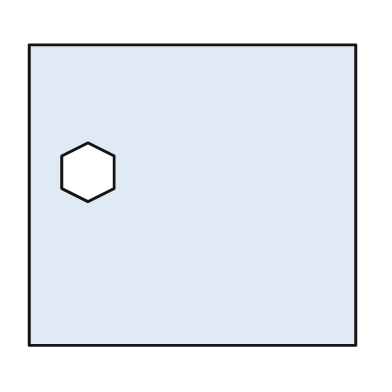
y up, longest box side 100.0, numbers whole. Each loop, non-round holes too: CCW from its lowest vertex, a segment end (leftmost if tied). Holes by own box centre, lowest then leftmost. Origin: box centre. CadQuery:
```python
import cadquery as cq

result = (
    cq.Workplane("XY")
    .moveTo(-50.0, -46.0)
    .lineTo(50.0, -46.0)
    .lineTo(50.0, 46.0)
    .lineTo(-50.0, 46.0)
    .close()
    .moveTo(-32.0, -2.0)
    .lineTo(-24.0, 2.0)
    .lineTo(-24.0, 12.0)
    .lineTo(-32.0, 16.0)
    .lineTo(-40.0, 12.0)
    .lineTo(-40.0, 2.0)
    .close()
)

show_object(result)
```